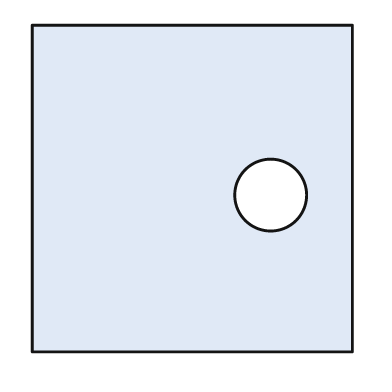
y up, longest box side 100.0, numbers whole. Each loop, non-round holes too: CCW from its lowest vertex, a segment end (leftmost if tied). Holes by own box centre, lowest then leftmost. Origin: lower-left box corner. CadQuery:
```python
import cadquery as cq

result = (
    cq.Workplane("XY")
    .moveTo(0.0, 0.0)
    .lineTo(98.0, 0.0)
    .lineTo(98.0, 100.0)
    .lineTo(0.0, 100.0)
    .close()
    .moveTo(73.0, 48.0)
    .circle(11.0)
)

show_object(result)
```